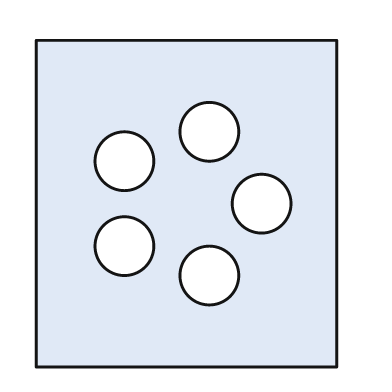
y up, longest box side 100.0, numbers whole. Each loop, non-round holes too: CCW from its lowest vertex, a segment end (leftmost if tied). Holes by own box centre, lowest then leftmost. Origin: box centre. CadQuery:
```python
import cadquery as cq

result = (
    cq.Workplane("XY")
    .moveTo(-46.0, -50.0)
    .lineTo(46.0, -50.0)
    .lineTo(46.0, 50.0)
    .lineTo(-46.0, 50.0)
    .close()
    .moveTo(7.0, -22.0)
    .circle(9.0)
    .moveTo(-19.0, -13.0)
    .circle(9.0)
    .moveTo(23.0, 0.0)
    .circle(9.0)
    .moveTo(-19.0, 13.0)
    .circle(9.0)
    .moveTo(7.0, 22.0)
    .circle(9.0)
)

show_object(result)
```